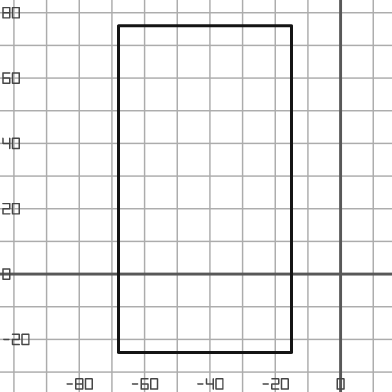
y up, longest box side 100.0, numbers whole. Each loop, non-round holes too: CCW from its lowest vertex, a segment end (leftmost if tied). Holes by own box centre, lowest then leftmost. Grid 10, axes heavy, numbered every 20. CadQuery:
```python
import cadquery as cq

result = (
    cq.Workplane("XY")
    .moveTo(-68.0, -24.0)
    .lineTo(-15.0, -24.0)
    .lineTo(-15.0, 76.0)
    .lineTo(-68.0, 76.0)
    .close()
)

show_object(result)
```